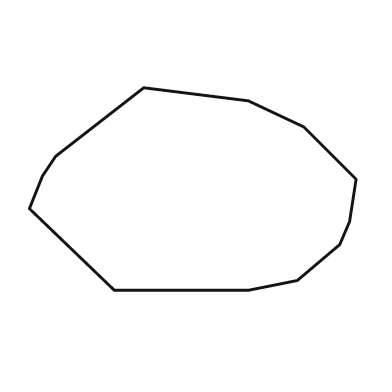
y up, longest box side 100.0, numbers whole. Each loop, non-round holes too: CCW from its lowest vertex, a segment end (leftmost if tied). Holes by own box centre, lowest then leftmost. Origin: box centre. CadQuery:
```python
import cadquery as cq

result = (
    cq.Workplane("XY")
    .moveTo(-24.0, -31.0)
    .lineTo(17.0, -31.0)
    .lineTo(32.0, -28.0)
    .lineTo(45.0, -17.0)
    .lineTo(48.0, -10.0)
    .lineTo(50.0, 3.0)
    .lineTo(34.0, 19.0)
    .lineTo(17.0, 27.0)
    .lineTo(-15.0, 31.0)
    .lineTo(-42.0, 10.0)
    .lineTo(-46.0, 4.0)
    .lineTo(-50.0, -6.0)
    .close()
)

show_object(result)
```